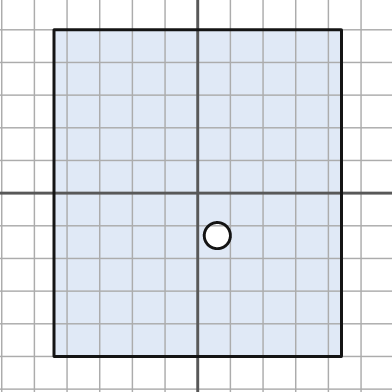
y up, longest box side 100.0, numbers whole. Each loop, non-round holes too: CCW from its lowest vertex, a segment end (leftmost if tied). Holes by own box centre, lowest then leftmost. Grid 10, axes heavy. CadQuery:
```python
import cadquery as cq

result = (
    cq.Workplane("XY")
    .moveTo(-44.0, -50.0)
    .lineTo(44.0, -50.0)
    .lineTo(44.0, 50.0)
    .lineTo(-44.0, 50.0)
    .close()
    .moveTo(6.0, -13.0)
    .circle(4.0)
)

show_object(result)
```